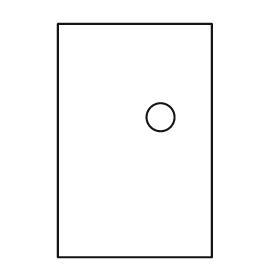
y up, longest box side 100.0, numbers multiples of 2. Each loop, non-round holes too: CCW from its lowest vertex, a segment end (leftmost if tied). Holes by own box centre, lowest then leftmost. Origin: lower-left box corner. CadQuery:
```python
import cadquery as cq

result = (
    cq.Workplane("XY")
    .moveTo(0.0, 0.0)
    .lineTo(66.0, 0.0)
    .lineTo(66.0, 100.0)
    .lineTo(0.0, 100.0)
    .close()
    .moveTo(44.0, 60.0)
    .circle(6.0)
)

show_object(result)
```